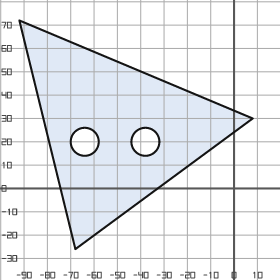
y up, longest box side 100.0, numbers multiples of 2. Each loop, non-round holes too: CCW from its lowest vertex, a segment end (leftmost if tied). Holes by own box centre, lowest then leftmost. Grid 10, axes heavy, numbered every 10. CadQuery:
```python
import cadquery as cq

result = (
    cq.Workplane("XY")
    .moveTo(-68.0, -26.0)
    .lineTo(8.0, 30.0)
    .lineTo(-92.0, 72.0)
    .close()
    .moveTo(-64.0, 20.0)
    .circle(6.0)
    .moveTo(-38.0, 20.0)
    .circle(6.0)
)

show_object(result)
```